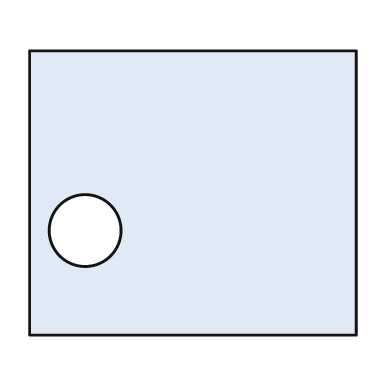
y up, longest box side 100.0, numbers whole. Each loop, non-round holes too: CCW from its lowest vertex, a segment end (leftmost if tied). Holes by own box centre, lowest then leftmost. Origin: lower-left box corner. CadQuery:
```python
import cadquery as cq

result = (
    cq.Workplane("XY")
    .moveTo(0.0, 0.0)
    .lineTo(100.0, 0.0)
    .lineTo(100.0, 87.0)
    .lineTo(0.0, 87.0)
    .close()
    .moveTo(17.0, 32.0)
    .circle(11.0)
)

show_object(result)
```